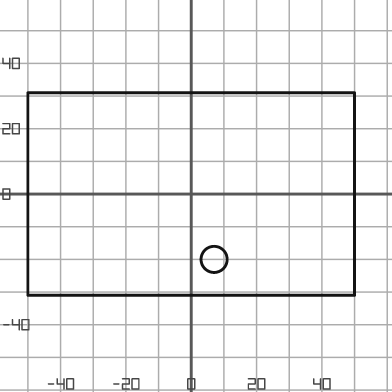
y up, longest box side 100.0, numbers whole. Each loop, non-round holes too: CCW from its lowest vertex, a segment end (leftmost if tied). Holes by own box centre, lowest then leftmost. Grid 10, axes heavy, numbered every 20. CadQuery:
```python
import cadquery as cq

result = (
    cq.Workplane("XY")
    .moveTo(-50.0, -31.0)
    .lineTo(50.0, -31.0)
    .lineTo(50.0, 31.0)
    .lineTo(-50.0, 31.0)
    .close()
    .moveTo(7.0, -20.0)
    .circle(4.0)
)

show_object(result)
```